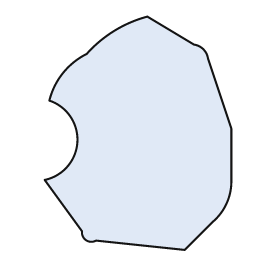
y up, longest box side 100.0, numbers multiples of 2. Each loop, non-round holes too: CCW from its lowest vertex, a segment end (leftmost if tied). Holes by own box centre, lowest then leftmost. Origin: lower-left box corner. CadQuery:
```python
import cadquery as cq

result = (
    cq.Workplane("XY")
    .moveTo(60.0, 0.0)
    .lineTo(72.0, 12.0)
    .threePointArc((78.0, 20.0), (80.0, 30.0))
    .lineTo(80.0, 52.0)
    .lineTo(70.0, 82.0)
    .threePointArc((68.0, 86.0), (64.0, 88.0))
    .lineTo(44.0, 100.0)
    .threePointArc((30.0, 94.0), (18.0, 84.0))
    .threePointArc((8.0, 76.0), (2.0, 64.0))
    .threePointArc((14.0, 46.0), (0.0, 30.0))
    .lineTo(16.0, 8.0)
    .threePointArc((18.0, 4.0), (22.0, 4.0))
    .close()
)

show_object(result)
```